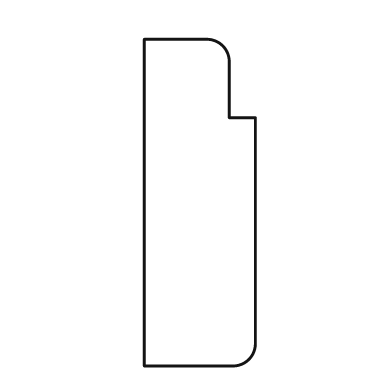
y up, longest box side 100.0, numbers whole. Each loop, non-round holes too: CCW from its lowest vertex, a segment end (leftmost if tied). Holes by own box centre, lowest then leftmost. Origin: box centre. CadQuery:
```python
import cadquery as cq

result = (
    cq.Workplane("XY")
    .moveTo(-17.0, -50.0)
    .lineTo(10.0, -50.0)
    .threePointArc((15.0, -48.0), (17.0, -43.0))
    .lineTo(17.0, 26.0)
    .lineTo(9.0, 26.0)
    .lineTo(9.0, 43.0)
    .threePointArc((7.0, 48.0), (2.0, 50.0))
    .lineTo(-17.0, 50.0)
    .close()
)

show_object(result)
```